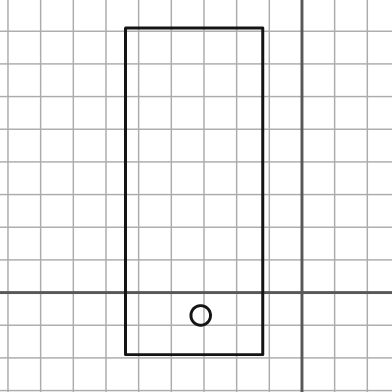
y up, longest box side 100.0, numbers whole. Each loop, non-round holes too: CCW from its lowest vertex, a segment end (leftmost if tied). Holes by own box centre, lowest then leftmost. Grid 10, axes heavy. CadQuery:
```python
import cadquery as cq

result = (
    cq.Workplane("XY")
    .moveTo(-54.0, -19.0)
    .lineTo(-12.0, -19.0)
    .lineTo(-12.0, 81.0)
    .lineTo(-54.0, 81.0)
    .close()
    .moveTo(-31.0, -7.0)
    .circle(3.0)
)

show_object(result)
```